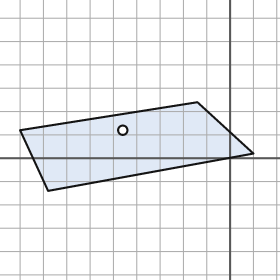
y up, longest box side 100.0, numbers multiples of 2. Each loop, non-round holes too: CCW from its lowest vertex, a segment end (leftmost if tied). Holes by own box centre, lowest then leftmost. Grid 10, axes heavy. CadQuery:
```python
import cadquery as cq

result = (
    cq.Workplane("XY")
    .moveTo(-78.0, -14.0)
    .lineTo(10.0, 2.0)
    .lineTo(-14.0, 24.0)
    .lineTo(-90.0, 12.0)
    .close()
    .moveTo(-46.0, 12.0)
    .circle(2.0)
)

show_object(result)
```